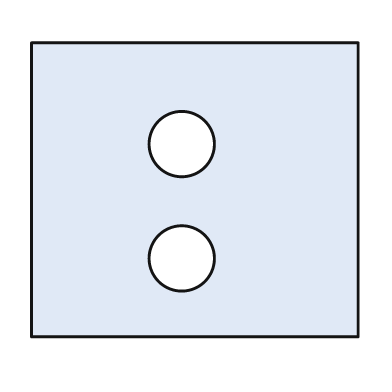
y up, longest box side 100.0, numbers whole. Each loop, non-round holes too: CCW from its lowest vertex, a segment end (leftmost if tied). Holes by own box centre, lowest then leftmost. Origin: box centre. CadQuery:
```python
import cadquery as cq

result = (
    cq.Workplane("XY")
    .moveTo(-50.0, -45.0)
    .lineTo(50.0, -45.0)
    .lineTo(50.0, 45.0)
    .lineTo(-50.0, 45.0)
    .close()
    .moveTo(-4.0, -21.0)
    .circle(10.0)
    .moveTo(-4.0, 14.0)
    .circle(10.0)
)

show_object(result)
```